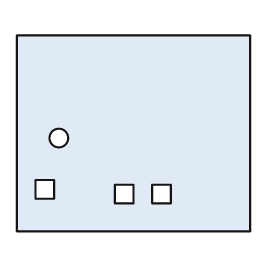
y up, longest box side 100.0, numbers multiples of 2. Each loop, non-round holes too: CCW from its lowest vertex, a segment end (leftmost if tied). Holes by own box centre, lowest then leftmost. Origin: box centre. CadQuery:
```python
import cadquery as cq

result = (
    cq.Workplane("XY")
    .moveTo(-50.0, -42.0)
    .lineTo(50.0, -42.0)
    .lineTo(50.0, 42.0)
    .lineTo(-50.0, 42.0)
    .close()
    .moveTo(-8.0, -30.0)
    .lineTo(0.0, -30.0)
    .lineTo(0.0, -22.0)
    .lineTo(-8.0, -22.0)
    .close()
    .moveTo(8.0, -30.0)
    .lineTo(16.0, -30.0)
    .lineTo(16.0, -22.0)
    .lineTo(8.0, -22.0)
    .close()
    .moveTo(-42.0, -28.0)
    .lineTo(-34.0, -28.0)
    .lineTo(-34.0, -20.0)
    .lineTo(-42.0, -20.0)
    .close()
    .moveTo(-32.0, -2.0)
    .circle(4.0)
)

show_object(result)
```